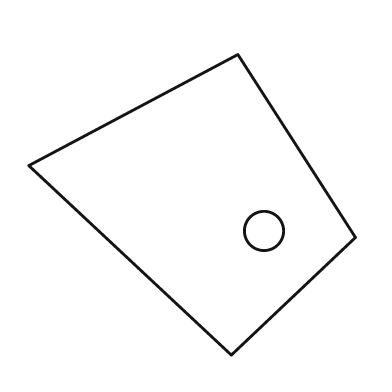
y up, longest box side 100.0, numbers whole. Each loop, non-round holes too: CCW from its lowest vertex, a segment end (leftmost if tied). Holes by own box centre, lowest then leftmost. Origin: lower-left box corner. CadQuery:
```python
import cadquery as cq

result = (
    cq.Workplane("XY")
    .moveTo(62.0, 0.0)
    .lineTo(100.0, 36.0)
    .lineTo(64.0, 92.0)
    .lineTo(0.0, 58.0)
    .close()
    .moveTo(72.0, 38.0)
    .circle(6.0)
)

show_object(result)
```